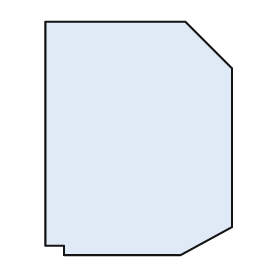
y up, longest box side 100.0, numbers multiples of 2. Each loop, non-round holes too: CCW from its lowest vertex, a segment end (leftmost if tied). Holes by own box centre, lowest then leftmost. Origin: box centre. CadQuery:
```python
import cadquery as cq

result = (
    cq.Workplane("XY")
    .moveTo(-32.0, -50.0)
    .lineTo(18.0, -50.0)
    .lineTo(40.0, -38.0)
    .lineTo(40.0, 30.0)
    .lineTo(20.0, 50.0)
    .lineTo(-40.0, 50.0)
    .lineTo(-40.0, -46.0)
    .lineTo(-32.0, -46.0)
    .close()
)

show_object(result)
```